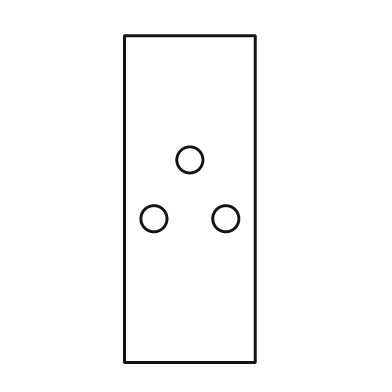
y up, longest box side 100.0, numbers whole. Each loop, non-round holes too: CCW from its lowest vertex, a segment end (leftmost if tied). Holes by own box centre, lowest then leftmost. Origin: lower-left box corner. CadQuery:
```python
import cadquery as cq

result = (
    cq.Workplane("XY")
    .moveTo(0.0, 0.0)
    .lineTo(40.0, 0.0)
    .lineTo(40.0, 100.0)
    .lineTo(0.0, 100.0)
    .close()
    .moveTo(9.0, 44.0)
    .circle(4.0)
    .moveTo(31.0, 44.0)
    .circle(4.0)
    .moveTo(20.0, 62.0)
    .circle(4.0)
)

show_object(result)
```